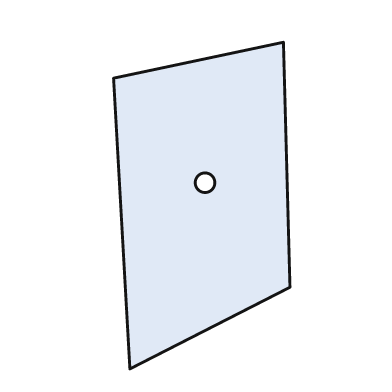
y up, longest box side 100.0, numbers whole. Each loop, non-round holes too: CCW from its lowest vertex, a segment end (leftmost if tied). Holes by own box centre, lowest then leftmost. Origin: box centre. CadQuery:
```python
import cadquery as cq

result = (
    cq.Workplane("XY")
    .moveTo(-22.0, -50.0)
    .lineTo(27.0, -25.0)
    .lineTo(25.0, 50.0)
    .lineTo(-27.0, 39.0)
    .close()
    .moveTo(1.0, 7.0)
    .circle(3.0)
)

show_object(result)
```